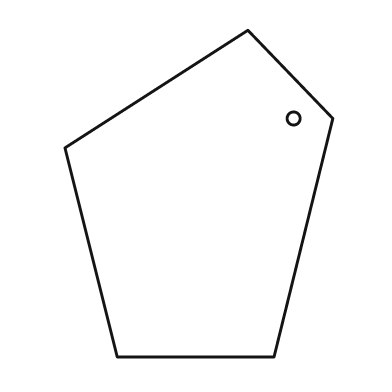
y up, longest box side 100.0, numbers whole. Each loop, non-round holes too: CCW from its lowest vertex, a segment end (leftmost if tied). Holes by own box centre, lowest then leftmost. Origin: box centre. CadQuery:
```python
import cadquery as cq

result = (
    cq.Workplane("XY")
    .moveTo(-25.0, -50.0)
    .lineTo(23.0, -50.0)
    .lineTo(41.0, 23.0)
    .lineTo(15.0, 50.0)
    .lineTo(-41.0, 14.0)
    .close()
    .moveTo(29.0, 23.0)
    .circle(2.0)
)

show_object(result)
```